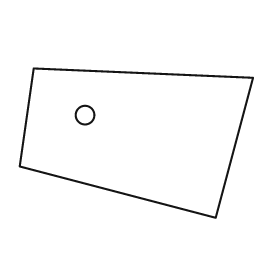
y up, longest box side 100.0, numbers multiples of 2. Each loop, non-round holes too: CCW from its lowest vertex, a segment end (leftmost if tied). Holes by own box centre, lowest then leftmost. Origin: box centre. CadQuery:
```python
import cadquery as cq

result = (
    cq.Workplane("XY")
    .moveTo(34.0, -32.0)
    .lineTo(50.0, 28.0)
    .lineTo(-44.0, 32.0)
    .lineTo(-50.0, -10.0)
    .close()
    .moveTo(-22.0, 12.0)
    .circle(4.0)
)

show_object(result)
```